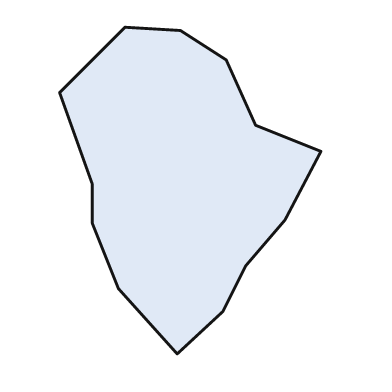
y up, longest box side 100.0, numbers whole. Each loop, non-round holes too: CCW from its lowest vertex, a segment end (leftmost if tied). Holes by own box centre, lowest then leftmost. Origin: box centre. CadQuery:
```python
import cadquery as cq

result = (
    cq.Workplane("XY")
    .moveTo(-4.0, -50.0)
    .lineTo(10.0, -37.0)
    .lineTo(17.0, -23.0)
    .lineTo(29.0, -9.0)
    .lineTo(40.0, 12.0)
    .lineTo(20.0, 20.0)
    .lineTo(11.0, 40.0)
    .lineTo(-3.0, 49.0)
    .lineTo(-20.0, 50.0)
    .lineTo(-40.0, 30.0)
    .lineTo(-30.0, 2.0)
    .lineTo(-30.0, -10.0)
    .lineTo(-22.0, -30.0)
    .close()
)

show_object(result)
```